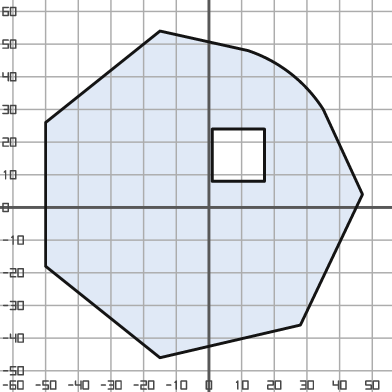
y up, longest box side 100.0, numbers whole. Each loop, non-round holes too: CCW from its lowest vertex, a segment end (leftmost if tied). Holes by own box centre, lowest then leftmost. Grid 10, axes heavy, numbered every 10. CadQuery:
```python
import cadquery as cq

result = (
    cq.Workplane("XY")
    .moveTo(-15.0, -46.0)
    .lineTo(28.0, -36.0)
    .lineTo(47.0, 4.0)
    .lineTo(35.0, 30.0)
    .threePointArc((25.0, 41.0), (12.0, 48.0))
    .lineTo(-15.0, 54.0)
    .lineTo(-50.0, 26.0)
    .lineTo(-50.0, -18.0)
    .close()
    .moveTo(1.0, 8.0)
    .lineTo(17.0, 8.0)
    .lineTo(17.0, 24.0)
    .lineTo(1.0, 24.0)
    .close()
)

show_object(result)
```